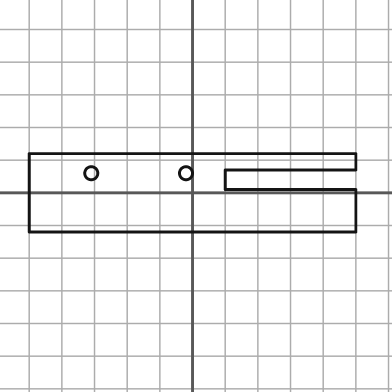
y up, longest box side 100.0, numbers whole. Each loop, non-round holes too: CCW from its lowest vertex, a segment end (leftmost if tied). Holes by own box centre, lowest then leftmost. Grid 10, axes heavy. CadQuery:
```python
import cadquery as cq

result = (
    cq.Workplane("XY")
    .moveTo(-50.0, -12.0)
    .lineTo(50.0, -12.0)
    .lineTo(50.0, 1.0)
    .lineTo(10.0, 1.0)
    .lineTo(10.0, 7.0)
    .lineTo(50.0, 7.0)
    .lineTo(50.0, 12.0)
    .lineTo(-50.0, 12.0)
    .close()
    .moveTo(-31.0, 6.0)
    .circle(2.0)
    .moveTo(-2.0, 6.0)
    .circle(2.0)
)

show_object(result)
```